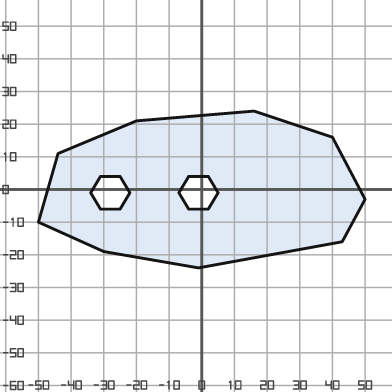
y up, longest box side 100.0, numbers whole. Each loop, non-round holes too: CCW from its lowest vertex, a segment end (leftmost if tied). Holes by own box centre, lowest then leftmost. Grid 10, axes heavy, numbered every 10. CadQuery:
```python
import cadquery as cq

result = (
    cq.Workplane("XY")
    .moveTo(-1.0, -24.0)
    .lineTo(43.0, -16.0)
    .lineTo(50.0, -3.0)
    .lineTo(40.0, 16.0)
    .lineTo(16.0, 24.0)
    .lineTo(-20.0, 21.0)
    .lineTo(-44.0, 11.0)
    .lineTo(-50.0, -10.0)
    .lineTo(-30.0, -19.0)
    .close()
    .moveTo(-31.0, -6.0)
    .lineTo(-25.0, -6.0)
    .lineTo(-22.0, -1.0)
    .lineTo(-25.0, 4.0)
    .lineTo(-31.0, 4.0)
    .lineTo(-34.0, -1.0)
    .close()
    .moveTo(-4.0, -6.0)
    .lineTo(2.0, -6.0)
    .lineTo(5.0, -1.0)
    .lineTo(2.0, 4.0)
    .lineTo(-4.0, 4.0)
    .lineTo(-7.0, -1.0)
    .close()
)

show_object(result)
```